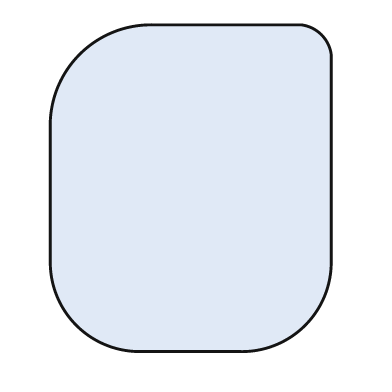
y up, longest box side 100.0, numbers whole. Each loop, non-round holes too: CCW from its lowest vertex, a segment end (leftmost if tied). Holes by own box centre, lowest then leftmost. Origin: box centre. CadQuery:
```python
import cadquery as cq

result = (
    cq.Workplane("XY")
    .moveTo(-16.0, -50.0)
    .lineTo(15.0, -50.0)
    .threePointArc((35.0, -42.0), (43.0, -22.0))
    .lineTo(43.0, 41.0)
    .threePointArc((40.0, 47.0), (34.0, 50.0))
    .lineTo(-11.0, 50.0)
    .threePointArc((-34.0, 41.0), (-43.0, 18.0))
    .lineTo(-43.0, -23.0)
    .threePointArc((-35.0, -42.0), (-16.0, -50.0))
    .close()
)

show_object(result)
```